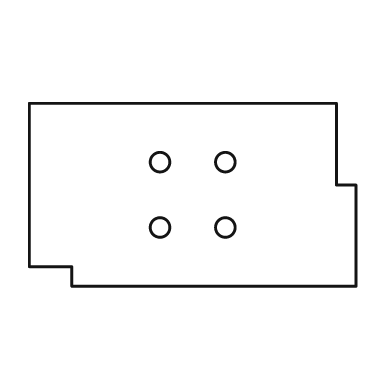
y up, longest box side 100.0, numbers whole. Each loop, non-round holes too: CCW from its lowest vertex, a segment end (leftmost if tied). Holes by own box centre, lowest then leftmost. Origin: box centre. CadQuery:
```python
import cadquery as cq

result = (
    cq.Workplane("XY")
    .moveTo(-37.0, -28.0)
    .lineTo(50.0, -28.0)
    .lineTo(50.0, 3.0)
    .lineTo(44.0, 3.0)
    .lineTo(44.0, 28.0)
    .lineTo(-50.0, 28.0)
    .lineTo(-50.0, -22.0)
    .lineTo(-37.0, -22.0)
    .close()
    .moveTo(-10.0, -10.0)
    .circle(3.0)
    .moveTo(10.0, -10.0)
    .circle(3.0)
    .moveTo(-10.0, 10.0)
    .circle(3.0)
    .moveTo(10.0, 10.0)
    .circle(3.0)
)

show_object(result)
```